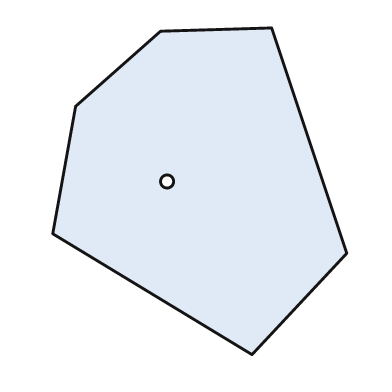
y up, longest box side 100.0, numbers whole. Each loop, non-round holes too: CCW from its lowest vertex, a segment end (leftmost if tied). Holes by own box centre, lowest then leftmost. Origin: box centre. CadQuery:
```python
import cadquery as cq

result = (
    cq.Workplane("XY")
    .moveTo(16.0, -50.0)
    .lineTo(45.0, -19.0)
    .lineTo(22.0, 50.0)
    .lineTo(-12.0, 49.0)
    .lineTo(-38.0, 26.0)
    .lineTo(-45.0, -13.0)
    .close()
    .moveTo(-10.0, 3.0)
    .circle(2.0)
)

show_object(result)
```